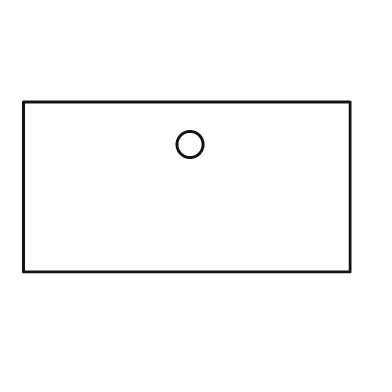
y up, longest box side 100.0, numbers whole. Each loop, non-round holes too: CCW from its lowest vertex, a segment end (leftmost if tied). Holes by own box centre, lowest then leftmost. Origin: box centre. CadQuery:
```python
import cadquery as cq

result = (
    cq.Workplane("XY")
    .moveTo(-50.0, -26.0)
    .lineTo(50.0, -26.0)
    .lineTo(50.0, 26.0)
    .lineTo(-50.0, 26.0)
    .close()
    .moveTo(1.0, 13.0)
    .circle(4.0)
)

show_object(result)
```